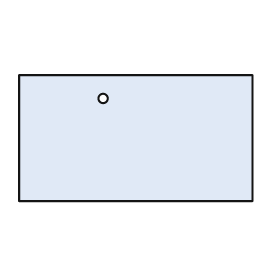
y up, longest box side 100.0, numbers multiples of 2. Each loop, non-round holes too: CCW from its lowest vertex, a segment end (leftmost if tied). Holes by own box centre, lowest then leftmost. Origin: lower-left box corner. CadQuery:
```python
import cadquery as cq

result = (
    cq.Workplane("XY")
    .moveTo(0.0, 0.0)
    .lineTo(100.0, 0.0)
    .lineTo(100.0, 54.0)
    .lineTo(0.0, 54.0)
    .close()
    .moveTo(36.0, 44.0)
    .circle(2.0)
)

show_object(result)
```